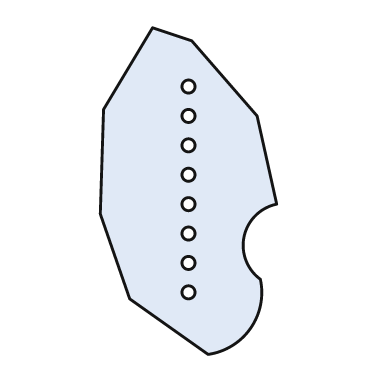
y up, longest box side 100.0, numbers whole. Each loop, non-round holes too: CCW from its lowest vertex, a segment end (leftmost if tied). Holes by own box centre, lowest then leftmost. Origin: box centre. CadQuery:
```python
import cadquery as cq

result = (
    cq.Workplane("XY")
    .moveTo(6.0, -50.0)
    .threePointArc((19.0, -42.0), (22.0, -27.0))
    .threePointArc((17.0, -14.0), (27.0, -4.0))
    .lineTo(21.0, 23.0)
    .lineTo(1.0, 46.0)
    .lineTo(-11.0, 50.0)
    .lineTo(-26.0, 25.0)
    .lineTo(-27.0, -7.0)
    .lineTo(-18.0, -33.0)
    .close()
    .moveTo(0.0, -31.0)
    .circle(2.0)
    .moveTo(0.0, -22.0)
    .circle(2.0)
    .moveTo(0.0, -13.0)
    .circle(2.0)
    .moveTo(0.0, -4.0)
    .circle(2.0)
    .moveTo(0.0, 5.0)
    .circle(2.0)
    .moveTo(0.0, 14.0)
    .circle(2.0)
    .moveTo(0.0, 23.0)
    .circle(2.0)
    .moveTo(0.0, 32.0)
    .circle(2.0)
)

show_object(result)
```